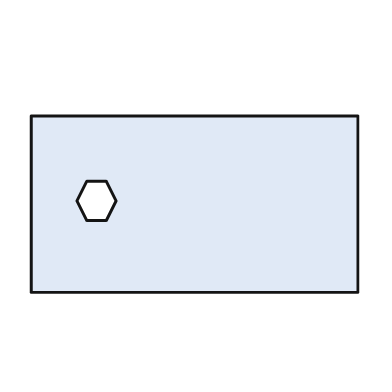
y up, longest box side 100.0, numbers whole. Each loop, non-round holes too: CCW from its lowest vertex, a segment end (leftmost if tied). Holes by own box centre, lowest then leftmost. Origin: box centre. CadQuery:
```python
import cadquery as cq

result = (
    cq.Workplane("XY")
    .moveTo(-50.0, -27.0)
    .lineTo(50.0, -27.0)
    .lineTo(50.0, 27.0)
    .lineTo(-50.0, 27.0)
    .close()
    .moveTo(-33.0, -5.0)
    .lineTo(-27.0, -5.0)
    .lineTo(-24.0, 1.0)
    .lineTo(-27.0, 7.0)
    .lineTo(-33.0, 7.0)
    .lineTo(-36.0, 1.0)
    .close()
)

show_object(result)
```